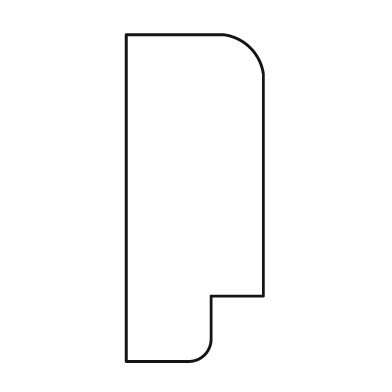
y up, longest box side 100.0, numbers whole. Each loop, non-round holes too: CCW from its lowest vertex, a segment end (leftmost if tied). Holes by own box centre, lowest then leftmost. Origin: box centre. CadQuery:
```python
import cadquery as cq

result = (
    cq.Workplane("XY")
    .moveTo(-21.0, -50.0)
    .lineTo(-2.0, -50.0)
    .threePointArc((3.0, -48.0), (5.0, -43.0))
    .lineTo(5.0, -30.0)
    .lineTo(21.0, -30.0)
    .lineTo(21.0, 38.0)
    .threePointArc((17.0, 46.0), (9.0, 50.0))
    .lineTo(-21.0, 50.0)
    .close()
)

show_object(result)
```